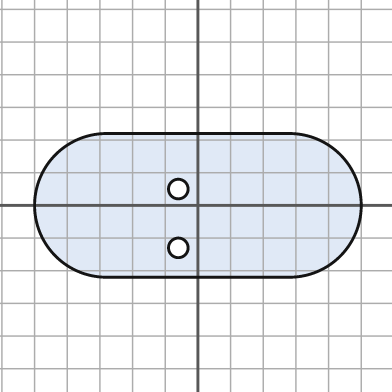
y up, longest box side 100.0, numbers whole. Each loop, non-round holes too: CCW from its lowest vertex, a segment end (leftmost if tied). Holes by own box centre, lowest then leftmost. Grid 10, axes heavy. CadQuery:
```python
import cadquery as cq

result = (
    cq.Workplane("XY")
    .moveTo(-28.0, -22.0)
    .lineTo(28.0, -22.0)
    .threePointArc((50.0, 0.0), (28.0, 22.0))
    .lineTo(-28.0, 22.0)
    .threePointArc((-50.0, 0.0), (-28.0, -22.0))
    .close()
    .moveTo(-6.0, -13.0)
    .circle(3.0)
    .moveTo(-6.0, 5.0)
    .circle(3.0)
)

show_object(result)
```